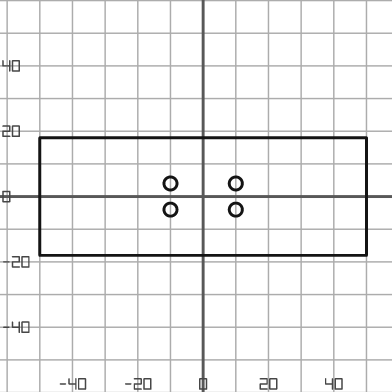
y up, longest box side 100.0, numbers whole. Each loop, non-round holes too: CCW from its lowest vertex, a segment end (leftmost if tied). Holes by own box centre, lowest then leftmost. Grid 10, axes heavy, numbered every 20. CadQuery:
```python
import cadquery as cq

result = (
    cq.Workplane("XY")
    .moveTo(-50.0, -18.0)
    .lineTo(50.0, -18.0)
    .lineTo(50.0, 18.0)
    .lineTo(-50.0, 18.0)
    .close()
    .moveTo(-10.0, -4.0)
    .circle(2.0)
    .moveTo(10.0, -4.0)
    .circle(2.0)
    .moveTo(-10.0, 4.0)
    .circle(2.0)
    .moveTo(10.0, 4.0)
    .circle(2.0)
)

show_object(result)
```